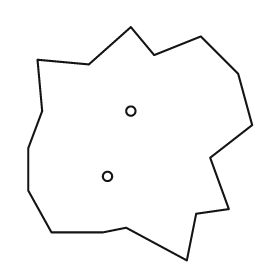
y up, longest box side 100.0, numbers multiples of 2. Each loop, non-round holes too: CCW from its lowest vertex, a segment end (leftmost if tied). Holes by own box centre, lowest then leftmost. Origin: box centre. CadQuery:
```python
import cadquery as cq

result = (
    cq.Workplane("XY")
    .moveTo(20.0, -50.0)
    .lineTo(24.0, -30.0)
    .lineTo(38.0, -28.0)
    .lineTo(30.0, -6.0)
    .lineTo(48.0, 8.0)
    .lineTo(42.0, 30.0)
    .lineTo(26.0, 46.0)
    .lineTo(6.0, 38.0)
    .lineTo(-4.0, 50.0)
    .lineTo(-22.0, 34.0)
    .lineTo(-44.0, 36.0)
    .lineTo(-42.0, 14.0)
    .lineTo(-48.0, -2.0)
    .lineTo(-48.0, -20.0)
    .lineTo(-38.0, -38.0)
    .lineTo(-16.0, -38.0)
    .lineTo(-6.0, -36.0)
    .close()
    .moveTo(-14.0, -14.0)
    .circle(2.0)
    .moveTo(-4.0, 14.0)
    .circle(2.0)
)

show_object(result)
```